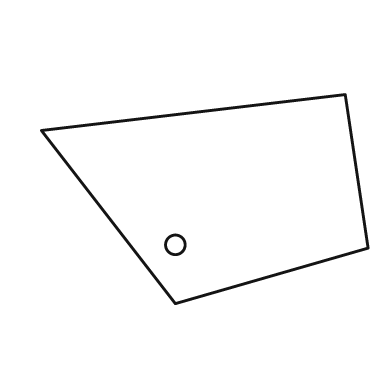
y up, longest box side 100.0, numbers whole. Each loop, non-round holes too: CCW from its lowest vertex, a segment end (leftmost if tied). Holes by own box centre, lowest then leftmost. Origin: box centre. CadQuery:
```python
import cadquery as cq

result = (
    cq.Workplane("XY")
    .moveTo(-9.0, -32.0)
    .lineTo(50.0, -15.0)
    .lineTo(43.0, 32.0)
    .lineTo(-50.0, 21.0)
    .close()
    .moveTo(-9.0, -14.0)
    .circle(3.0)
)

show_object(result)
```